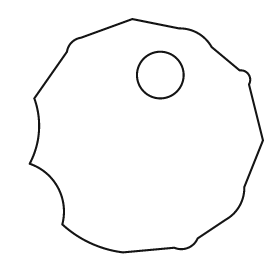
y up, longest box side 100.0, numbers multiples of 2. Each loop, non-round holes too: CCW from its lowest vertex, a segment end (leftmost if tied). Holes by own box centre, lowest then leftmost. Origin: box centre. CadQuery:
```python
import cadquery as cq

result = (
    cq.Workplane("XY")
    .moveTo(-10.0, -50.0)
    .lineTo(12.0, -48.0)
    .threePointArc((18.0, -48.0), (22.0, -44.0))
    .lineTo(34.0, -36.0)
    .threePointArc((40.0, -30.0), (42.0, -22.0))
    .lineTo(50.0, -2.0)
    .lineTo(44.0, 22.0)
    .threePointArc((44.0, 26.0), (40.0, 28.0))
    .lineTo(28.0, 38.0)
    .threePointArc((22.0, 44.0), (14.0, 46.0))
    .lineTo(-6.0, 50.0)
    .lineTo(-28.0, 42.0)
    .threePointArc((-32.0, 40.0), (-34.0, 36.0))
    .lineTo(-48.0, 16.0)
    .threePointArc((-46.0, 2.0), (-50.0, -12.0))
    .threePointArc((-38.0, -22.0), (-36.0, -38.0))
    .threePointArc((-24.0, -46.0), (-10.0, -50.0))
    .close()
    .moveTo(6.0, 26.0)
    .circle(10.0)
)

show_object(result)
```